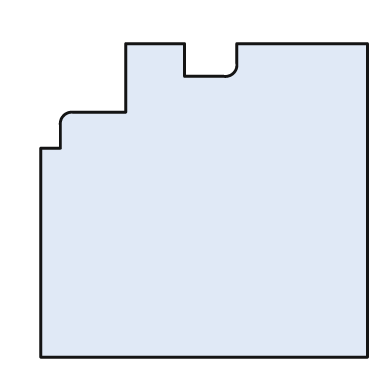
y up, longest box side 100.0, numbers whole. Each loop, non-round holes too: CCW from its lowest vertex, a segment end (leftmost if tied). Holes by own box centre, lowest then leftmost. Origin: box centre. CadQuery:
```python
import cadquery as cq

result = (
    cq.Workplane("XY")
    .moveTo(-50.0, -48.0)
    .lineTo(50.0, -48.0)
    .lineTo(50.0, 48.0)
    .lineTo(10.0, 48.0)
    .lineTo(10.0, 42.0)
    .threePointArc((9.0, 39.0), (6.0, 38.0))
    .lineTo(-6.0, 38.0)
    .lineTo(-6.0, 48.0)
    .lineTo(-24.0, 48.0)
    .lineTo(-24.0, 27.0)
    .lineTo(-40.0, 27.0)
    .threePointArc((-43.0, 26.0), (-44.0, 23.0))
    .lineTo(-44.0, 16.0)
    .lineTo(-50.0, 16.0)
    .close()
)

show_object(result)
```